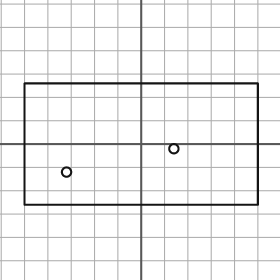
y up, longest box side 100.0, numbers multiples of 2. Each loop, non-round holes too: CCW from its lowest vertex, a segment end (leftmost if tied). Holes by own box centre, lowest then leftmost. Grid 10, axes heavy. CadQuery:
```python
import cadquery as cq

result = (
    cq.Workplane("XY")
    .moveTo(-50.0, -26.0)
    .lineTo(50.0, -26.0)
    .lineTo(50.0, 26.0)
    .lineTo(-50.0, 26.0)
    .close()
    .moveTo(-32.0, -12.0)
    .circle(2.0)
    .moveTo(14.0, -2.0)
    .circle(2.0)
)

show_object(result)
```